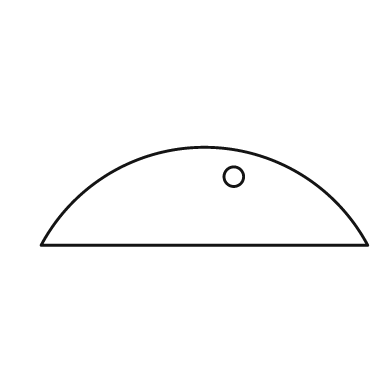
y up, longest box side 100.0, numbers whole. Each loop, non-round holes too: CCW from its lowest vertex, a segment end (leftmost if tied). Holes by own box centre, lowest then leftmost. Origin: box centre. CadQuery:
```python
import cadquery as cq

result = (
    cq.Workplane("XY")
    .moveTo(-50.0, -15.0)
    .lineTo(50.0, -15.0)
    .threePointArc((0.0, 15.0), (-50.0, -15.0))
    .close()
    .moveTo(9.0, 6.0)
    .circle(3.0)
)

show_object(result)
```